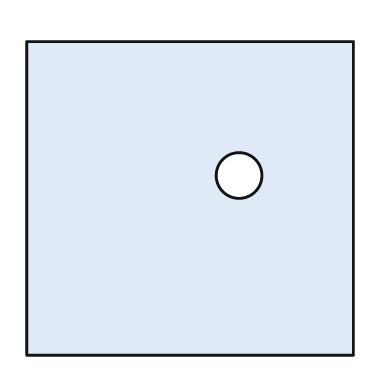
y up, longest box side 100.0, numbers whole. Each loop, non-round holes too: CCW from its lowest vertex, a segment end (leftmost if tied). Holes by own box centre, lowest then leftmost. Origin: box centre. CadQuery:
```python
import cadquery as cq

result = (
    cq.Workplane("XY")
    .moveTo(-50.0, -48.0)
    .lineTo(50.0, -48.0)
    .lineTo(50.0, 48.0)
    .lineTo(-50.0, 48.0)
    .close()
    .moveTo(15.0, 7.0)
    .circle(7.0)
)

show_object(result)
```